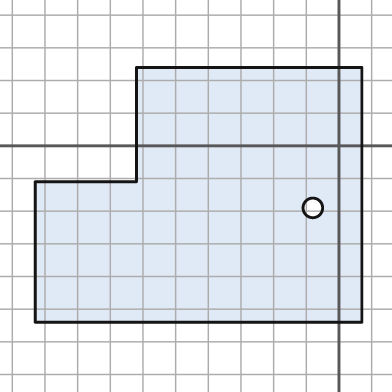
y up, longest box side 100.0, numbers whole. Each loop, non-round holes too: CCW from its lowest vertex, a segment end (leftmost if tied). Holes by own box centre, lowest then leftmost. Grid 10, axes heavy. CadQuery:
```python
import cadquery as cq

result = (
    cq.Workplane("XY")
    .moveTo(-93.0, -54.0)
    .lineTo(7.0, -54.0)
    .lineTo(7.0, 24.0)
    .lineTo(-62.0, 24.0)
    .lineTo(-62.0, -11.0)
    .lineTo(-93.0, -11.0)
    .close()
    .moveTo(-8.0, -19.0)
    .circle(3.0)
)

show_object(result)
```